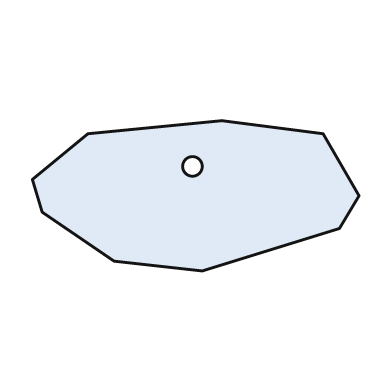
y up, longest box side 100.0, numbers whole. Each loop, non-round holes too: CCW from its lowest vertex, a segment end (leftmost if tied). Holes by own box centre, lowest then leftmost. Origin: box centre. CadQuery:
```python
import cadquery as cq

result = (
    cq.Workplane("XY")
    .moveTo(2.0, -23.0)
    .lineTo(44.0, -10.0)
    .lineTo(50.0, 0.0)
    .lineTo(39.0, 19.0)
    .lineTo(8.0, 23.0)
    .lineTo(-33.0, 19.0)
    .lineTo(-50.0, 5.0)
    .lineTo(-47.0, -5.0)
    .lineTo(-25.0, -20.0)
    .close()
    .moveTo(-1.0, 9.0)
    .circle(3.0)
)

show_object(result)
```